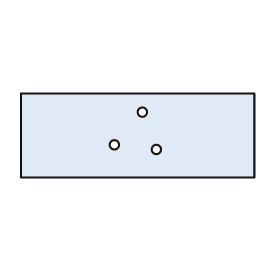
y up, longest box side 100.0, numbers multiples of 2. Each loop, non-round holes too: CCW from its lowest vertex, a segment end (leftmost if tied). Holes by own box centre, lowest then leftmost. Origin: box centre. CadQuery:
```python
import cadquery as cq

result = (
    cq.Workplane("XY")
    .moveTo(-50.0, -18.0)
    .lineTo(50.0, -18.0)
    .lineTo(50.0, 18.0)
    .lineTo(-50.0, 18.0)
    .close()
    .moveTo(8.0, -6.0)
    .circle(2.0)
    .moveTo(-10.0, -4.0)
    .circle(2.0)
    .moveTo(2.0, 10.0)
    .circle(2.0)
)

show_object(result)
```